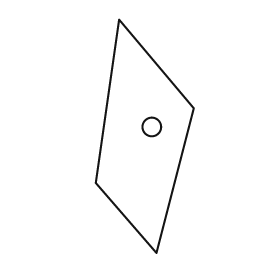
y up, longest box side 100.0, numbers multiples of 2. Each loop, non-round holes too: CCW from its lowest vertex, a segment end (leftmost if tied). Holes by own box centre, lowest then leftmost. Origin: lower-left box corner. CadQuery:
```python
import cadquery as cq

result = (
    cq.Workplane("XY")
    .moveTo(26.0, 0.0)
    .lineTo(42.0, 62.0)
    .lineTo(10.0, 100.0)
    .lineTo(0.0, 30.0)
    .close()
    .moveTo(24.0, 54.0)
    .circle(4.0)
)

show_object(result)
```